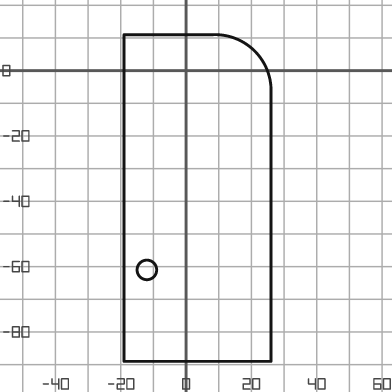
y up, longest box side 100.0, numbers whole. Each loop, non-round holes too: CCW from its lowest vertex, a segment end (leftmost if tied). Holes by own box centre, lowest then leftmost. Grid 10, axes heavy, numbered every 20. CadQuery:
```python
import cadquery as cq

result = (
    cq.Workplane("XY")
    .moveTo(-19.0, -89.0)
    .lineTo(26.0, -89.0)
    .lineTo(26.0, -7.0)
    .threePointArc((21.0, 6.0), (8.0, 11.0))
    .lineTo(-19.0, 11.0)
    .close()
    .moveTo(-12.0, -61.0)
    .circle(3.0)
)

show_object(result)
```